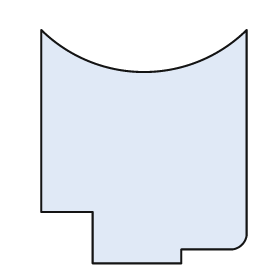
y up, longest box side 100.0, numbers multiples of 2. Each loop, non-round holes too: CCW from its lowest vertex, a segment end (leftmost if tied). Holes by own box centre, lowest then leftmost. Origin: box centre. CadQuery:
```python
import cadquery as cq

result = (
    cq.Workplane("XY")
    .moveTo(-22.0, -50.0)
    .lineTo(16.0, -50.0)
    .lineTo(16.0, -44.0)
    .lineTo(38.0, -44.0)
    .threePointArc((42.0, -42.0), (44.0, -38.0))
    .lineTo(44.0, 50.0)
    .threePointArc((0.0, 32.0), (-44.0, 50.0))
    .lineTo(-44.0, -28.0)
    .lineTo(-22.0, -28.0)
    .close()
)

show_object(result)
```